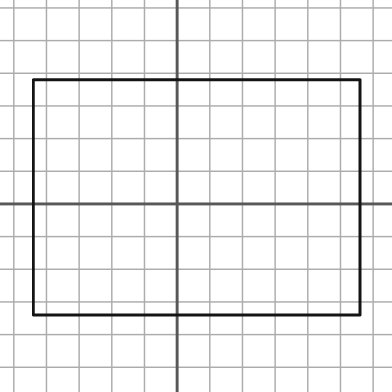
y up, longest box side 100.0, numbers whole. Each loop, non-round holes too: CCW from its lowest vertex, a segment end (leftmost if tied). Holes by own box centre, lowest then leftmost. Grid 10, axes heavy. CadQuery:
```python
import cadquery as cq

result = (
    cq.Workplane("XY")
    .moveTo(-44.0, -34.0)
    .lineTo(56.0, -34.0)
    .lineTo(56.0, 38.0)
    .lineTo(-44.0, 38.0)
    .close()
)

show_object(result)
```